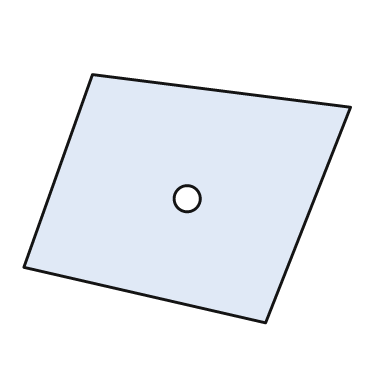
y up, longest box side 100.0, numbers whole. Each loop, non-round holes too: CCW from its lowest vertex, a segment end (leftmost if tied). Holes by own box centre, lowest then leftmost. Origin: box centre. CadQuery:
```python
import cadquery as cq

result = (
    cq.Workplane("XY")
    .moveTo(24.0, -38.0)
    .lineTo(50.0, 28.0)
    .lineTo(-29.0, 38.0)
    .lineTo(-50.0, -21.0)
    .close()
    .moveTo(0.0, 0.0)
    .circle(4.0)
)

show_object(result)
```